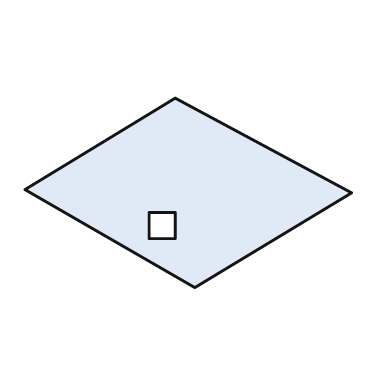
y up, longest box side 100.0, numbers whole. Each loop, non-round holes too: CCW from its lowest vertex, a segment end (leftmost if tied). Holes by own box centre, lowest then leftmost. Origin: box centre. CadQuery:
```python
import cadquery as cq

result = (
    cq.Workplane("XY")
    .moveTo(2.0, -29.0)
    .lineTo(50.0, 0.0)
    .lineTo(-4.0, 29.0)
    .lineTo(-50.0, 1.0)
    .close()
    .moveTo(-12.0, -14.0)
    .lineTo(-4.0, -14.0)
    .lineTo(-4.0, -6.0)
    .lineTo(-12.0, -6.0)
    .close()
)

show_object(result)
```